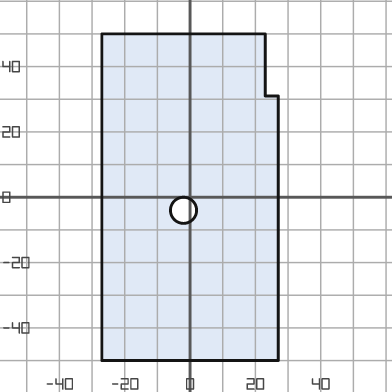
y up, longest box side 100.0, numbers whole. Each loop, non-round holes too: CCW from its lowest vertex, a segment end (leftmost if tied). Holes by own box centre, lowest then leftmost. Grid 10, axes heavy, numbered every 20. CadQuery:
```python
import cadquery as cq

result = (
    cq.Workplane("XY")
    .moveTo(-27.0, -50.0)
    .lineTo(27.0, -50.0)
    .lineTo(27.0, 31.0)
    .lineTo(23.0, 31.0)
    .lineTo(23.0, 50.0)
    .lineTo(-27.0, 50.0)
    .close()
    .moveTo(-2.0, -4.0)
    .circle(4.0)
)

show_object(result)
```